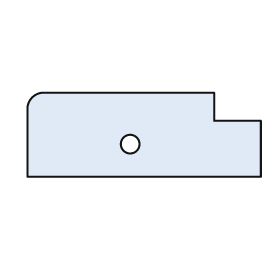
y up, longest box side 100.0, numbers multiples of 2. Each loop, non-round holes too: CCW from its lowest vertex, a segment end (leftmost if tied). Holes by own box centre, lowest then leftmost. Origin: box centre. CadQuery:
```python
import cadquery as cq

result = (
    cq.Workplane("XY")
    .moveTo(-50.0, -18.0)
    .lineTo(50.0, -18.0)
    .lineTo(50.0, 6.0)
    .lineTo(30.0, 6.0)
    .lineTo(30.0, 18.0)
    .lineTo(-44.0, 18.0)
    .threePointArc((-48.0, 16.0), (-50.0, 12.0))
    .close()
    .moveTo(-6.0, -4.0)
    .circle(4.0)
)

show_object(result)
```